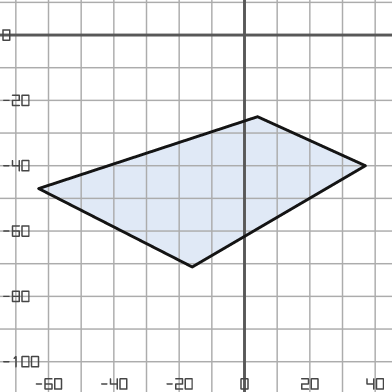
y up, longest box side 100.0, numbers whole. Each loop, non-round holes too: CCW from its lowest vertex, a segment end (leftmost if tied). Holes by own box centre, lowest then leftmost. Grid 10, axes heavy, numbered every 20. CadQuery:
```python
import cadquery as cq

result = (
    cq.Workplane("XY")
    .moveTo(-16.0, -71.0)
    .lineTo(37.0, -40.0)
    .lineTo(4.0, -25.0)
    .lineTo(-63.0, -47.0)
    .close()
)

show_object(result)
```